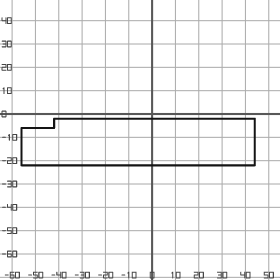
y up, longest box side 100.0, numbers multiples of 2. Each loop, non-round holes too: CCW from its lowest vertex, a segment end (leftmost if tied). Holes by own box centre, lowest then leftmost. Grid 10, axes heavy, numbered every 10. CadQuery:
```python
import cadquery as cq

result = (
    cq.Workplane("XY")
    .moveTo(-56.0, -22.0)
    .lineTo(44.0, -22.0)
    .lineTo(44.0, -2.0)
    .lineTo(-42.0, -2.0)
    .lineTo(-42.0, -6.0)
    .lineTo(-56.0, -6.0)
    .close()
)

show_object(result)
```